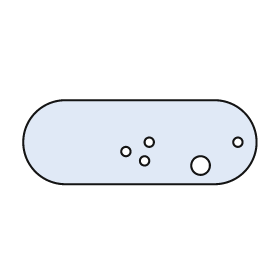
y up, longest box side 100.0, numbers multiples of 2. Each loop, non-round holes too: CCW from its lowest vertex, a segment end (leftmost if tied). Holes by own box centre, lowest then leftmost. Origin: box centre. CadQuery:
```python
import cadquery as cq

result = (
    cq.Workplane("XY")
    .moveTo(-32.0, -18.0)
    .lineTo(32.0, -18.0)
    .threePointArc((50.0, 0.0), (32.0, 18.0))
    .lineTo(-32.0, 18.0)
    .threePointArc((-50.0, 0.0), (-32.0, -18.0))
    .close()
    .moveTo(26.0, -10.0)
    .circle(4.0)
    .moveTo(2.0, -8.0)
    .circle(2.0)
    .moveTo(-6.0, -4.0)
    .circle(2.0)
    .moveTo(4.0, 0.0)
    .circle(2.0)
    .moveTo(42.0, 0.0)
    .circle(2.0)
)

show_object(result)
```